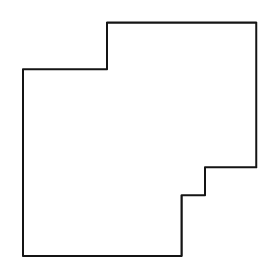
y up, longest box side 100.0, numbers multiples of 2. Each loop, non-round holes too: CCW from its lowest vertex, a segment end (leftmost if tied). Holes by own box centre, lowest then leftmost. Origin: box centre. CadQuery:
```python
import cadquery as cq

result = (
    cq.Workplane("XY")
    .moveTo(-50.0, -50.0)
    .lineTo(18.0, -50.0)
    .lineTo(18.0, -24.0)
    .lineTo(28.0, -24.0)
    .lineTo(28.0, -12.0)
    .lineTo(50.0, -12.0)
    .lineTo(50.0, 50.0)
    .lineTo(-14.0, 50.0)
    .lineTo(-14.0, 30.0)
    .lineTo(-50.0, 30.0)
    .close()
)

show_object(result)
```